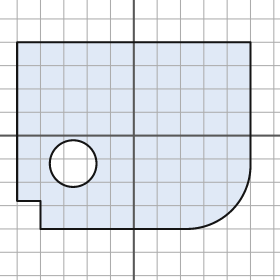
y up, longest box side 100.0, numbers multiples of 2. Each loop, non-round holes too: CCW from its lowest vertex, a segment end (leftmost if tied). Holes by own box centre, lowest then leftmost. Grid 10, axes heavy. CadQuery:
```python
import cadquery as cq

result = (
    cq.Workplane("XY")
    .moveTo(-40.0, -40.0)
    .lineTo(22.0, -40.0)
    .threePointArc((42.0, -32.0), (50.0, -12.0))
    .lineTo(50.0, 40.0)
    .lineTo(-50.0, 40.0)
    .lineTo(-50.0, -28.0)
    .lineTo(-40.0, -28.0)
    .close()
    .moveTo(-26.0, -12.0)
    .circle(10.0)
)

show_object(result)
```